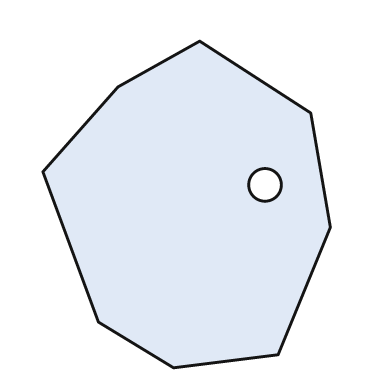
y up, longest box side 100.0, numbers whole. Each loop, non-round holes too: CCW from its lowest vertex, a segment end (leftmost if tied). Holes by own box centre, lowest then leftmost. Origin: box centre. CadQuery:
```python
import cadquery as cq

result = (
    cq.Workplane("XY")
    .moveTo(-4.0, -50.0)
    .lineTo(28.0, -46.0)
    .lineTo(44.0, -7.0)
    .lineTo(38.0, 28.0)
    .lineTo(4.0, 50.0)
    .lineTo(-21.0, 36.0)
    .lineTo(-44.0, 10.0)
    .lineTo(-27.0, -36.0)
    .close()
    .moveTo(24.0, 6.0)
    .circle(5.0)
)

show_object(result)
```